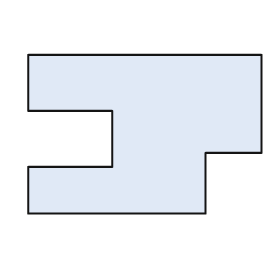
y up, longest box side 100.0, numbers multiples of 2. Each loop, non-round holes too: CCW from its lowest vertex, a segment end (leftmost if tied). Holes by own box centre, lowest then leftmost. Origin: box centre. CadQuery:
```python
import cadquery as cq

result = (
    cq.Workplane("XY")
    .moveTo(-50.0, -34.0)
    .lineTo(26.0, -34.0)
    .lineTo(26.0, -8.0)
    .lineTo(50.0, -8.0)
    .lineTo(50.0, 34.0)
    .lineTo(-50.0, 34.0)
    .lineTo(-50.0, 10.0)
    .lineTo(-14.0, 10.0)
    .lineTo(-14.0, -14.0)
    .lineTo(-50.0, -14.0)
    .close()
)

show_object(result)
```